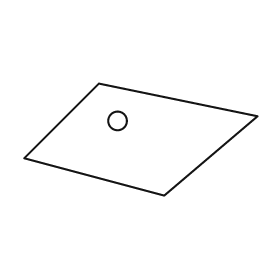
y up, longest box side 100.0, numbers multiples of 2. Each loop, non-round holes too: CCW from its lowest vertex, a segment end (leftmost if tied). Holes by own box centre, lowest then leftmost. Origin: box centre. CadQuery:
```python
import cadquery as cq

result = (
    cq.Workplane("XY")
    .moveTo(10.0, -24.0)
    .lineTo(50.0, 10.0)
    .lineTo(-18.0, 24.0)
    .lineTo(-50.0, -8.0)
    .close()
    .moveTo(-10.0, 8.0)
    .circle(4.0)
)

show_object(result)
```